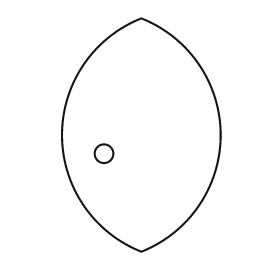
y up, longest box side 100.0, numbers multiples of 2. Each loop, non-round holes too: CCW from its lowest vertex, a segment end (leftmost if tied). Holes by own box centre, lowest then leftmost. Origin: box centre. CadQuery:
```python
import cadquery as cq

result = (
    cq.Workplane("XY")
    .moveTo(0.0, -50.0)
    .threePointArc((34.0, 0.0), (0.0, 50.0))
    .threePointArc((-34.0, 0.0), (0.0, -50.0))
    .close()
    .moveTo(-16.0, -8.0)
    .circle(4.0)
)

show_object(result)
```